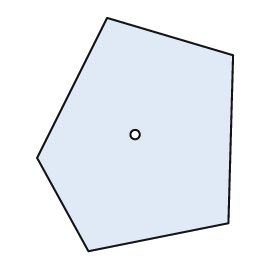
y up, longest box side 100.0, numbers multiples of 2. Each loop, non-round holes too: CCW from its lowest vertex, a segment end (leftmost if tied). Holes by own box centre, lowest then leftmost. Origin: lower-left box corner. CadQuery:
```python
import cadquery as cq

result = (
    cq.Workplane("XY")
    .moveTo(22.0, 0.0)
    .lineTo(82.0, 12.0)
    .lineTo(84.0, 84.0)
    .lineTo(30.0, 100.0)
    .lineTo(0.0, 40.0)
    .close()
    .moveTo(42.0, 50.0)
    .circle(2.0)
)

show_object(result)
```